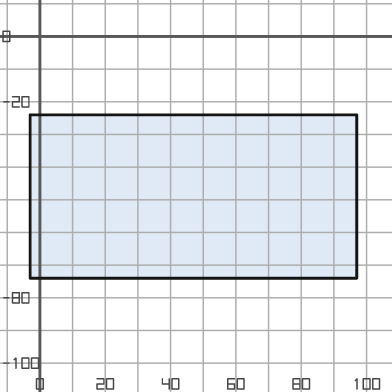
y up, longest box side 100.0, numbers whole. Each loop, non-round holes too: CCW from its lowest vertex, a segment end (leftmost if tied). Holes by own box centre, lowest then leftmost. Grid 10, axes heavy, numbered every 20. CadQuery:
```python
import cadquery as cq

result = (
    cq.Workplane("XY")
    .moveTo(-3.0, -74.0)
    .lineTo(97.0, -74.0)
    .lineTo(97.0, -24.0)
    .lineTo(-3.0, -24.0)
    .close()
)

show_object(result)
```